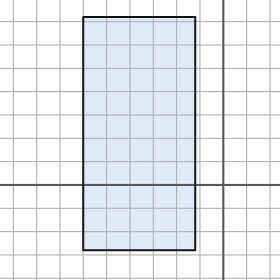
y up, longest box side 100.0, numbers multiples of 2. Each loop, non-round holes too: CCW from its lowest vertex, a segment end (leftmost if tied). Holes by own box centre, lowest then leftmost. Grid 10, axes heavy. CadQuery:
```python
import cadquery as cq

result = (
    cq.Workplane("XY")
    .moveTo(-60.0, -28.0)
    .lineTo(-12.0, -28.0)
    .lineTo(-12.0, 72.0)
    .lineTo(-60.0, 72.0)
    .close()
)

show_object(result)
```